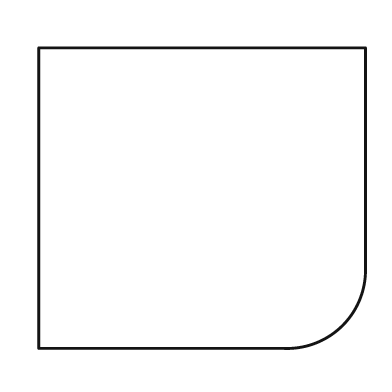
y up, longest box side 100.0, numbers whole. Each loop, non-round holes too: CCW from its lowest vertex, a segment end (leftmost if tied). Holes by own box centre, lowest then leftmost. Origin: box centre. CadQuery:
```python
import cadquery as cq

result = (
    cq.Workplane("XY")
    .moveTo(-50.0, -46.0)
    .lineTo(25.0, -46.0)
    .threePointArc((43.0, -39.0), (50.0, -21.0))
    .lineTo(50.0, 46.0)
    .lineTo(-50.0, 46.0)
    .close()
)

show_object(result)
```